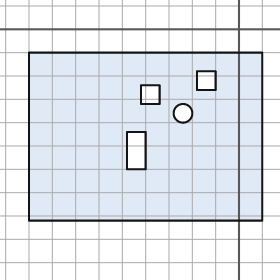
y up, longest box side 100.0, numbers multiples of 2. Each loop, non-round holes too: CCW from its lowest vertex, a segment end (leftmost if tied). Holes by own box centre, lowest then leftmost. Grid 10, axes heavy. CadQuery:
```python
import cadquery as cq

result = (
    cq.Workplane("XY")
    .moveTo(-90.0, -82.0)
    .lineTo(10.0, -82.0)
    .lineTo(10.0, -10.0)
    .lineTo(-90.0, -10.0)
    .close()
    .moveTo(-48.0, -60.0)
    .lineTo(-40.0, -60.0)
    .lineTo(-40.0, -44.0)
    .lineTo(-48.0, -44.0)
    .close()
    .moveTo(-24.0, -36.0)
    .circle(4.0)
    .moveTo(-42.0, -32.0)
    .lineTo(-34.0, -32.0)
    .lineTo(-34.0, -24.0)
    .lineTo(-42.0, -24.0)
    .close()
    .moveTo(-18.0, -26.0)
    .lineTo(-10.0, -26.0)
    .lineTo(-10.0, -18.0)
    .lineTo(-18.0, -18.0)
    .close()
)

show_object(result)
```